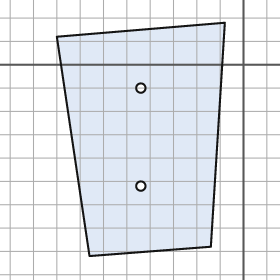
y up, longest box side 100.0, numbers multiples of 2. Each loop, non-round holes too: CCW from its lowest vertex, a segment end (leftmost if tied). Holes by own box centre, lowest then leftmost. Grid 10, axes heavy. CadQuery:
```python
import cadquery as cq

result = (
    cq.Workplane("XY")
    .moveTo(-66.0, -82.0)
    .lineTo(-14.0, -78.0)
    .lineTo(-8.0, 18.0)
    .lineTo(-80.0, 12.0)
    .close()
    .moveTo(-44.0, -52.0)
    .circle(2.0)
    .moveTo(-44.0, -10.0)
    .circle(2.0)
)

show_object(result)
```